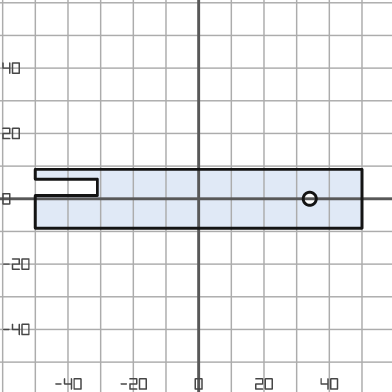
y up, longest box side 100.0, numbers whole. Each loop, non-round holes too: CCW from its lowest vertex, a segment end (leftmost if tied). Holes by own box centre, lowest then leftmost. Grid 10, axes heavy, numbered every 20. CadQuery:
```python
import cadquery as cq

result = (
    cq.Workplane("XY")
    .moveTo(-50.0, -9.0)
    .lineTo(50.0, -9.0)
    .lineTo(50.0, 9.0)
    .lineTo(-50.0, 9.0)
    .lineTo(-50.0, 6.0)
    .lineTo(-31.0, 6.0)
    .lineTo(-31.0, 1.0)
    .lineTo(-50.0, 1.0)
    .close()
    .moveTo(34.0, 0.0)
    .circle(2.0)
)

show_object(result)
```